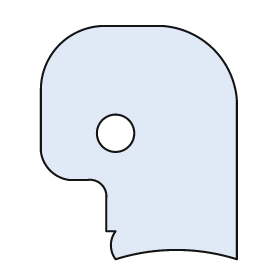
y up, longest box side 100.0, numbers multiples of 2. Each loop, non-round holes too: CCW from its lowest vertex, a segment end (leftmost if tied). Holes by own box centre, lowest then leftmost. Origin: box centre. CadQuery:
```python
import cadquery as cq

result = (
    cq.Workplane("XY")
    .moveTo(-10.0, -50.0)
    .threePointArc((16.0, -46.0), (42.0, -50.0))
    .lineTo(42.0, 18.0)
    .threePointArc((32.0, 40.0), (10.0, 50.0))
    .lineTo(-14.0, 50.0)
    .threePointArc((-34.0, 42.0), (-42.0, 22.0))
    .lineTo(-42.0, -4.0)
    .threePointArc((-38.0, -12.0), (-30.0, -16.0))
    .lineTo(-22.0, -16.0)
    .threePointArc((-16.0, -18.0), (-14.0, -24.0))
    .lineTo(-14.0, -38.0)
    .lineTo(-10.0, -38.0)
    .threePointArc((-12.0, -44.0), (-10.0, -50.0))
    .close()
    .moveTo(-10.0, 4.0)
    .circle(8.0)
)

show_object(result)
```